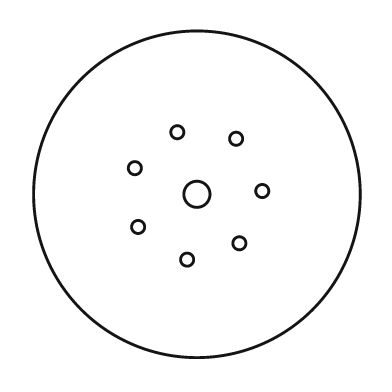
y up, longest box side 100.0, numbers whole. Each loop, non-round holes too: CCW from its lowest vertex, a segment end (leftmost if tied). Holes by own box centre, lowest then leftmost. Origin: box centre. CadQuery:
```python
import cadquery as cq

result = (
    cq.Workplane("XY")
    .moveTo(0.0, 0.0)
    .circle(50.0)
    .moveTo(-3.0, -20.0)
    .circle(2.0)
    .moveTo(13.0, -15.0)
    .circle(2.0)
    .moveTo(-18.0, -10.0)
    .circle(2.0)
    .moveTo(0.0, 0.0)
    .circle(4.0)
    .moveTo(20.0, 1.0)
    .circle(2.0)
    .moveTo(-19.0, 8.0)
    .circle(2.0)
    .moveTo(12.0, 17.0)
    .circle(2.0)
    .moveTo(-6.0, 19.0)
    .circle(2.0)
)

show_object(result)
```